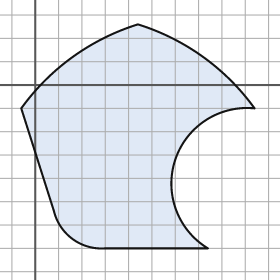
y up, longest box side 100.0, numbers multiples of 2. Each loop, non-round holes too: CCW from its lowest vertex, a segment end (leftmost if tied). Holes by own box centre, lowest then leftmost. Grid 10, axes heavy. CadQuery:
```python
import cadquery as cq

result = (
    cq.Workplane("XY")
    .moveTo(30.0, -70.0)
    .lineTo(74.0, -70.0)
    .threePointArc((60.0, -32.0), (94.0, -10.0))
    .threePointArc((72.0, 12.0), (44.0, 26.0))
    .threePointArc((16.0, 12.0), (-6.0, -10.0))
    .lineTo(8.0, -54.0)
    .threePointArc((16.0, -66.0), (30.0, -70.0))
    .close()
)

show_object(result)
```